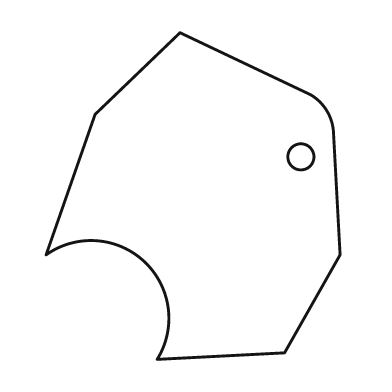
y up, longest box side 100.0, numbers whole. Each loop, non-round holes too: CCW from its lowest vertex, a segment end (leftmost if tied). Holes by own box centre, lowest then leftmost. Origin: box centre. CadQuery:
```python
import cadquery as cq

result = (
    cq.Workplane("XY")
    .moveTo(-11.0, -50.0)
    .lineTo(28.0, -48.0)
    .lineTo(45.0, -18.0)
    .lineTo(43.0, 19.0)
    .threePointArc((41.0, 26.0), (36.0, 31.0))
    .lineTo(-4.0, 50.0)
    .lineTo(-30.0, 25.0)
    .lineTo(-45.0, -18.0)
    .threePointArc((-15.0, -20.0), (-11.0, -50.0))
    .close()
    .moveTo(33.0, 12.0)
    .circle(4.0)
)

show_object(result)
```